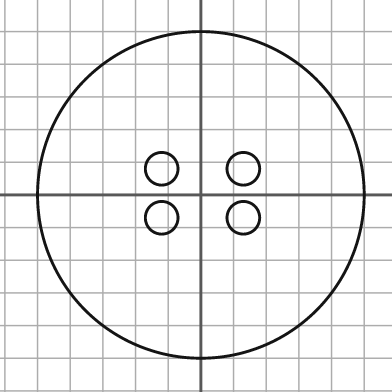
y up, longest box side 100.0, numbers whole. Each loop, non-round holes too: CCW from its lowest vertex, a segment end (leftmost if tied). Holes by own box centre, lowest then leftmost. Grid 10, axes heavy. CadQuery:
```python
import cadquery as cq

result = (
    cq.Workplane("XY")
    .moveTo(0.0, 0.0)
    .circle(50.0)
    .moveTo(-12.0, -7.0)
    .circle(5.0)
    .moveTo(13.0, -7.0)
    .circle(5.0)
    .moveTo(-12.0, 8.0)
    .circle(5.0)
    .moveTo(13.0, 8.0)
    .circle(5.0)
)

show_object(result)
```